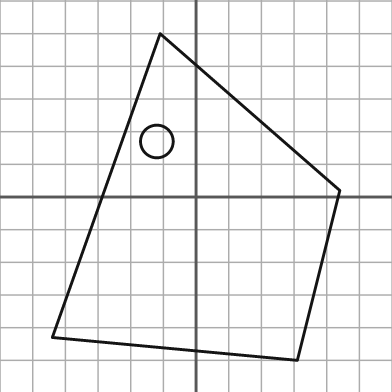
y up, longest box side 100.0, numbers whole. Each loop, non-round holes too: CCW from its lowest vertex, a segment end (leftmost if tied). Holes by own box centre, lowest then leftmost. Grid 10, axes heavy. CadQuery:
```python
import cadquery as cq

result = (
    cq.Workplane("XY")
    .moveTo(31.0, -50.0)
    .lineTo(44.0, 2.0)
    .lineTo(-11.0, 50.0)
    .lineTo(-44.0, -43.0)
    .close()
    .moveTo(-12.0, 17.0)
    .circle(5.0)
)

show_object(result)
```